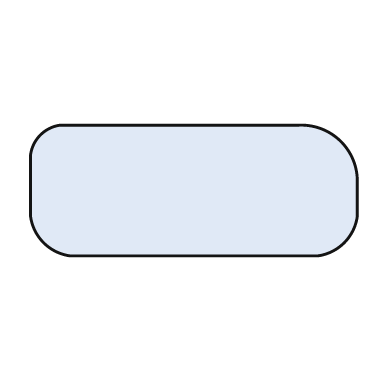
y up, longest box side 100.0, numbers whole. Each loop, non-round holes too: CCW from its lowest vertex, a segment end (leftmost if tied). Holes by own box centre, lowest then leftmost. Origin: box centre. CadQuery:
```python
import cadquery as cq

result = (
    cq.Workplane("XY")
    .moveTo(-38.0, -20.0)
    .lineTo(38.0, -20.0)
    .threePointArc((46.0, -16.0), (50.0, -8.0))
    .lineTo(50.0, 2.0)
    .threePointArc((45.0, 15.0), (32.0, 20.0))
    .lineTo(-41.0, 20.0)
    .threePointArc((-47.0, 17.0), (-50.0, 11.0))
    .lineTo(-50.0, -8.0)
    .threePointArc((-46.0, -16.0), (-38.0, -20.0))
    .close()
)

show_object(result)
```